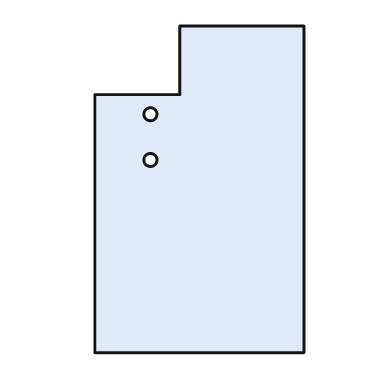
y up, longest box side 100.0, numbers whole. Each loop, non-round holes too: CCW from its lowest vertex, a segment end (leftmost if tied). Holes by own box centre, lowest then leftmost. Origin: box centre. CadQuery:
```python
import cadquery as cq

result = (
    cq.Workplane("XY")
    .moveTo(-32.0, -50.0)
    .lineTo(32.0, -50.0)
    .lineTo(32.0, 50.0)
    .lineTo(-6.0, 50.0)
    .lineTo(-6.0, 29.0)
    .lineTo(-32.0, 29.0)
    .close()
    .moveTo(-15.0, 9.0)
    .circle(2.0)
    .moveTo(-15.0, 23.0)
    .circle(2.0)
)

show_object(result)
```